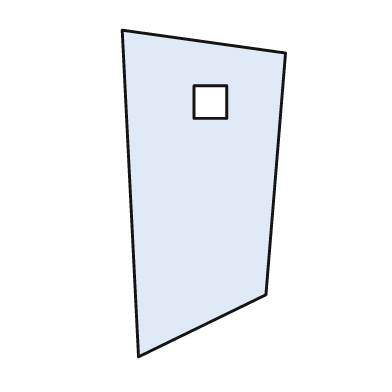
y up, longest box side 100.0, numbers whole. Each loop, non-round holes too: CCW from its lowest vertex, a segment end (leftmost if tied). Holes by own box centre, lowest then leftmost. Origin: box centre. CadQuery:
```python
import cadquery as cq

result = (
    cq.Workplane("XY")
    .moveTo(-20.0, -50.0)
    .lineTo(19.0, -31.0)
    .lineTo(25.0, 43.0)
    .lineTo(-25.0, 50.0)
    .close()
    .moveTo(-3.0, 23.0)
    .lineTo(7.0, 23.0)
    .lineTo(7.0, 33.0)
    .lineTo(-3.0, 33.0)
    .close()
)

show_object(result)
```